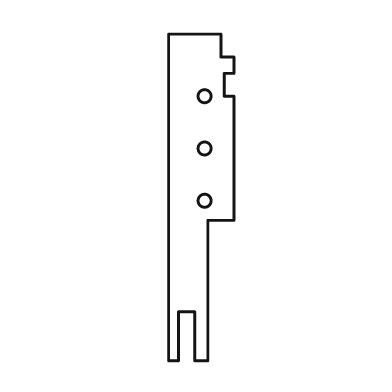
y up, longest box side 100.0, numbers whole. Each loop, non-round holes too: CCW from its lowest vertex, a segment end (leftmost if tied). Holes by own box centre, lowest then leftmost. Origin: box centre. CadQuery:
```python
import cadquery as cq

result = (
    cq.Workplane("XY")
    .moveTo(-10.0, -50.0)
    .lineTo(-7.0, -50.0)
    .lineTo(-7.0, -35.0)
    .lineTo(-2.0, -35.0)
    .lineTo(-2.0, -50.0)
    .lineTo(2.0, -50.0)
    .lineTo(2.0, -7.0)
    .lineTo(10.0, -7.0)
    .lineTo(10.0, 31.0)
    .lineTo(7.0, 31.0)
    .lineTo(7.0, 38.0)
    .lineTo(10.0, 38.0)
    .lineTo(10.0, 43.0)
    .lineTo(6.0, 43.0)
    .lineTo(6.0, 50.0)
    .lineTo(-10.0, 50.0)
    .close()
    .moveTo(1.0, -1.0)
    .circle(2.0)
    .moveTo(1.0, 15.0)
    .circle(2.0)
    .moveTo(1.0, 31.0)
    .circle(2.0)
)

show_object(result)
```